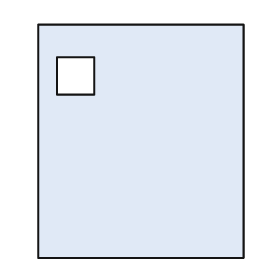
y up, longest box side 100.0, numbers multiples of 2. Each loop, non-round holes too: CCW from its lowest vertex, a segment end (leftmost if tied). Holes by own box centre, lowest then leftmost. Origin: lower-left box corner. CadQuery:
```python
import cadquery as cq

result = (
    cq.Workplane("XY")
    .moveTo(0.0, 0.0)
    .lineTo(88.0, 0.0)
    .lineTo(88.0, 100.0)
    .lineTo(0.0, 100.0)
    .close()
    .moveTo(8.0, 70.0)
    .lineTo(24.0, 70.0)
    .lineTo(24.0, 86.0)
    .lineTo(8.0, 86.0)
    .close()
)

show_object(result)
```